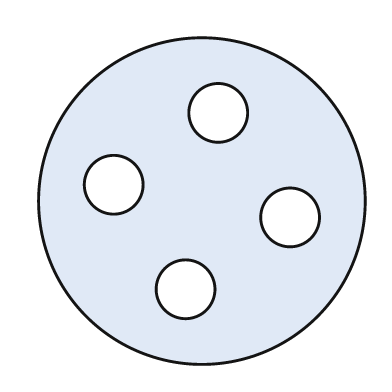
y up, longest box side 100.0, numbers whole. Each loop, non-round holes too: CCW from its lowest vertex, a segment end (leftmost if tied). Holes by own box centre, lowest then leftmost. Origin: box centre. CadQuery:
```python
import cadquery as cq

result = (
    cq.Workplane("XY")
    .moveTo(0.0, 0.0)
    .circle(50.0)
    .moveTo(-5.0, -27.0)
    .circle(9.0)
    .moveTo(27.0, -5.0)
    .circle(9.0)
    .moveTo(-27.0, 5.0)
    .circle(9.0)
    .moveTo(5.0, 27.0)
    .circle(9.0)
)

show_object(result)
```